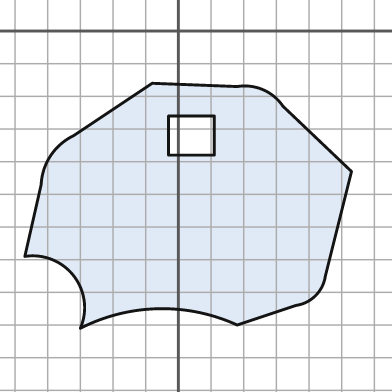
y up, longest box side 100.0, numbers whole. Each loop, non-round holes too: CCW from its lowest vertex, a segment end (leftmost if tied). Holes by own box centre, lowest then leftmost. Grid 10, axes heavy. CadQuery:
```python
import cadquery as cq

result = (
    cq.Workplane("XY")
    .moveTo(-30.0, -91.0)
    .threePointArc((-6.0, -85.0), (18.0, -90.0))
    .lineTo(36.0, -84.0)
    .threePointArc((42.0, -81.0), (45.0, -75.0))
    .lineTo(53.0, -43.0)
    .lineTo(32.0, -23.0)
    .threePointArc((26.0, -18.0), (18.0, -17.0))
    .lineTo(-8.0, -16.0)
    .lineTo(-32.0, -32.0)
    .threePointArc((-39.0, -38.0), (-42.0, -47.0))
    .lineTo(-47.0, -69.0)
    .threePointArc((-32.0, -75.0), (-30.0, -91.0))
    .close()
    .moveTo(-3.0, -38.0)
    .lineTo(11.0, -38.0)
    .lineTo(11.0, -26.0)
    .lineTo(-3.0, -26.0)
    .close()
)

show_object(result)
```